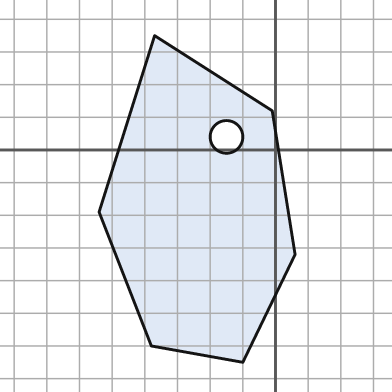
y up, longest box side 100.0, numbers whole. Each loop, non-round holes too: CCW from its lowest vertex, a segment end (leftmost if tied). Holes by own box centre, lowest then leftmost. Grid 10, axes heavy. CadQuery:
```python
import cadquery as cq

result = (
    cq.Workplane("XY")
    .moveTo(-10.0, -65.0)
    .lineTo(6.0, -32.0)
    .lineTo(-1.0, 12.0)
    .lineTo(-37.0, 35.0)
    .lineTo(-54.0, -19.0)
    .lineTo(-38.0, -60.0)
    .close()
    .moveTo(-15.0, 4.0)
    .circle(5.0)
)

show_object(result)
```